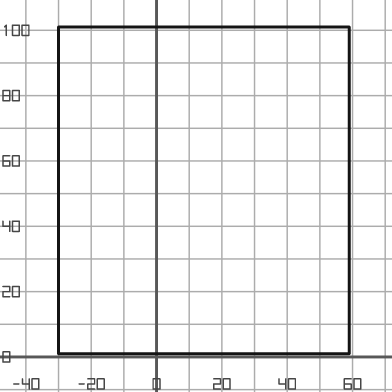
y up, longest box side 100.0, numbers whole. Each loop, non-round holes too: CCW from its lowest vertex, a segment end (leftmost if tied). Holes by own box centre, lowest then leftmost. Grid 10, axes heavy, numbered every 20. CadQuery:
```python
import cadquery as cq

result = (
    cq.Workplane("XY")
    .moveTo(-30.0, 1.0)
    .lineTo(59.0, 1.0)
    .lineTo(59.0, 101.0)
    .lineTo(-30.0, 101.0)
    .close()
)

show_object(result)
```